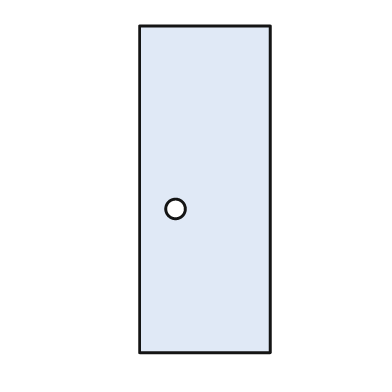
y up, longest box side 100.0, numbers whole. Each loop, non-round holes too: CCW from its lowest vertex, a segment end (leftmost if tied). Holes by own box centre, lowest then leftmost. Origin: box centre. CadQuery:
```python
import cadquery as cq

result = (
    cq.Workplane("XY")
    .moveTo(-20.0, -50.0)
    .lineTo(20.0, -50.0)
    .lineTo(20.0, 50.0)
    .lineTo(-20.0, 50.0)
    .close()
    .moveTo(-9.0, -6.0)
    .circle(3.0)
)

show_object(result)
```